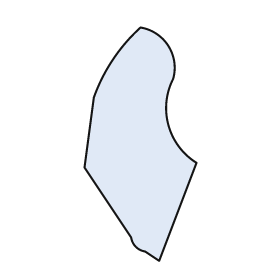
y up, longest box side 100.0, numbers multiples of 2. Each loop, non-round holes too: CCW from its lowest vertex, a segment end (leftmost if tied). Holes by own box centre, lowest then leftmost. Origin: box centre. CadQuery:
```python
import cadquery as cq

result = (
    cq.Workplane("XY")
    .moveTo(8.0, -50.0)
    .lineTo(24.0, -8.0)
    .threePointArc((12.0, 8.0), (14.0, 28.0))
    .threePointArc((12.0, 42.0), (0.0, 50.0))
    .threePointArc((-12.0, 36.0), (-20.0, 20.0))
    .lineTo(-24.0, -10.0)
    .lineTo(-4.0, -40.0)
    .threePointArc((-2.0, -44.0), (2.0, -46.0))
    .close()
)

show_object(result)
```